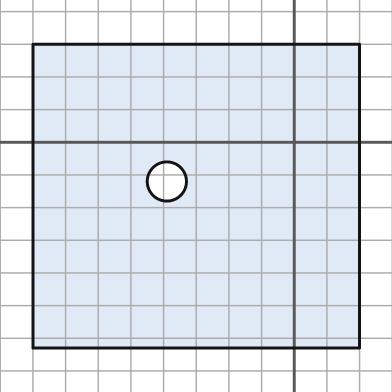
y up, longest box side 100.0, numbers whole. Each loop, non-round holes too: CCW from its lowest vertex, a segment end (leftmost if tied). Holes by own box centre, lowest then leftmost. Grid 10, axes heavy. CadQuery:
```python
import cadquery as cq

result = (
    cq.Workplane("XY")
    .moveTo(-80.0, -63.0)
    .lineTo(20.0, -63.0)
    .lineTo(20.0, 30.0)
    .lineTo(-80.0, 30.0)
    .close()
    .moveTo(-39.0, -12.0)
    .circle(6.0)
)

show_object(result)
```